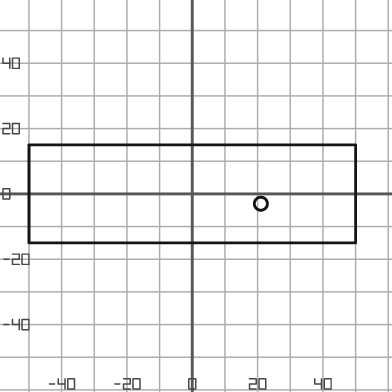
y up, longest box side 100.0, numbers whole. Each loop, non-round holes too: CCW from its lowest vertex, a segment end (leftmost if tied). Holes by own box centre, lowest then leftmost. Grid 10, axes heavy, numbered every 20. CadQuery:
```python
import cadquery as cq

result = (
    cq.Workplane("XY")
    .moveTo(-50.0, -15.0)
    .lineTo(50.0, -15.0)
    .lineTo(50.0, 15.0)
    .lineTo(-50.0, 15.0)
    .close()
    .moveTo(21.0, -3.0)
    .circle(2.0)
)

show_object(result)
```